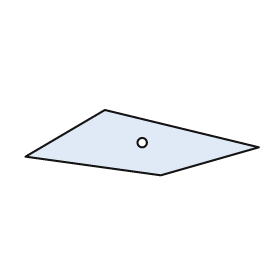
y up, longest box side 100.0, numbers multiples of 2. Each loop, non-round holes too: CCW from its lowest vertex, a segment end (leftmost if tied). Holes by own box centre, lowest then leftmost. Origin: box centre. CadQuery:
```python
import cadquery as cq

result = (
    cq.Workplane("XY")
    .moveTo(8.0, -14.0)
    .lineTo(50.0, -2.0)
    .lineTo(-16.0, 14.0)
    .lineTo(-50.0, -6.0)
    .close()
    .moveTo(0.0, 0.0)
    .circle(2.0)
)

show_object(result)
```